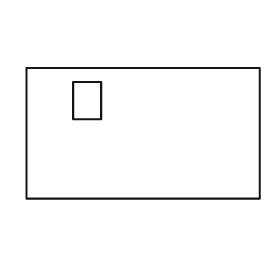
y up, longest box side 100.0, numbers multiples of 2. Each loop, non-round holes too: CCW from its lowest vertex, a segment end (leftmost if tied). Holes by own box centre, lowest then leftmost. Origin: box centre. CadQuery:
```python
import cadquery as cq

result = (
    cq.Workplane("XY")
    .moveTo(-50.0, -28.0)
    .lineTo(50.0, -28.0)
    .lineTo(50.0, 28.0)
    .lineTo(-50.0, 28.0)
    .close()
    .moveTo(-30.0, 6.0)
    .lineTo(-18.0, 6.0)
    .lineTo(-18.0, 22.0)
    .lineTo(-30.0, 22.0)
    .close()
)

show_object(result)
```